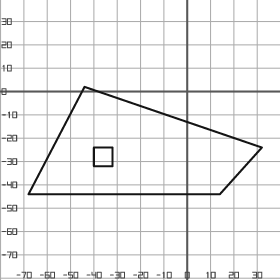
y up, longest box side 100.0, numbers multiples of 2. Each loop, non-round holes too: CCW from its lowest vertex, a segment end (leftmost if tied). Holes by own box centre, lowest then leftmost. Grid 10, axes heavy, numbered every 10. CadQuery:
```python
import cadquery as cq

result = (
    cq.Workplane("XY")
    .moveTo(-68.0, -44.0)
    .lineTo(14.0, -44.0)
    .lineTo(32.0, -24.0)
    .lineTo(-44.0, 2.0)
    .close()
    .moveTo(-40.0, -32.0)
    .lineTo(-32.0, -32.0)
    .lineTo(-32.0, -24.0)
    .lineTo(-40.0, -24.0)
    .close()
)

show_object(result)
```